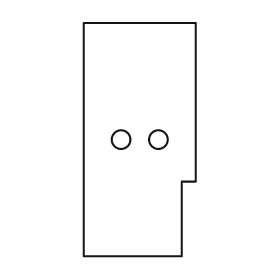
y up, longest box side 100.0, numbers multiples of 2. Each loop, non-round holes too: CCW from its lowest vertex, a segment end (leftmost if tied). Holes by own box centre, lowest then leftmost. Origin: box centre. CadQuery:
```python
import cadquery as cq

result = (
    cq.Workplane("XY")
    .moveTo(-24.0, -50.0)
    .lineTo(18.0, -50.0)
    .lineTo(18.0, -18.0)
    .lineTo(24.0, -18.0)
    .lineTo(24.0, 50.0)
    .lineTo(-24.0, 50.0)
    .close()
    .moveTo(-8.0, 0.0)
    .circle(4.0)
    .moveTo(8.0, 0.0)
    .circle(4.0)
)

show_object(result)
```